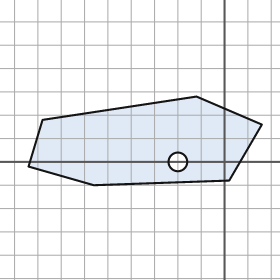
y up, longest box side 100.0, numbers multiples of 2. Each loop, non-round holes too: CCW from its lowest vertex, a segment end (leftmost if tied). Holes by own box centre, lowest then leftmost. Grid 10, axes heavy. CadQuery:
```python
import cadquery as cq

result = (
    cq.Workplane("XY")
    .moveTo(-56.0, -10.0)
    .lineTo(2.0, -8.0)
    .lineTo(16.0, 16.0)
    .lineTo(-12.0, 28.0)
    .lineTo(-78.0, 18.0)
    .lineTo(-84.0, -2.0)
    .close()
    .moveTo(-20.0, 0.0)
    .circle(4.0)
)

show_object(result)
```